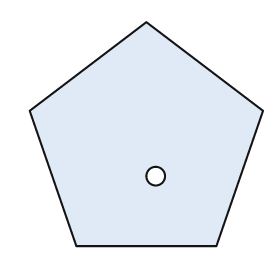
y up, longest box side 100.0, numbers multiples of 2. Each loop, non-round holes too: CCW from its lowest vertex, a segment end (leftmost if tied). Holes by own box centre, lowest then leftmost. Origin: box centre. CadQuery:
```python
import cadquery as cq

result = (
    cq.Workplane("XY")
    .moveTo(-30.0, -48.0)
    .lineTo(30.0, -48.0)
    .lineTo(50.0, 10.0)
    .lineTo(0.0, 48.0)
    .lineTo(-50.0, 10.0)
    .close()
    .moveTo(4.0, -18.0)
    .circle(4.0)
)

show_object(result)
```